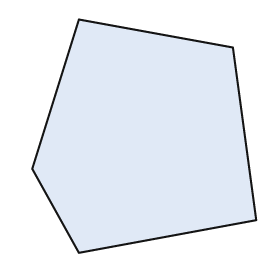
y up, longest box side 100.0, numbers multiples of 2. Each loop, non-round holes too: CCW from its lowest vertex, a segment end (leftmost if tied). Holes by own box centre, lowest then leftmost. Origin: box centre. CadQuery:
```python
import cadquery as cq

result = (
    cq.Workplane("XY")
    .moveTo(-28.0, -50.0)
    .lineTo(48.0, -36.0)
    .lineTo(38.0, 38.0)
    .lineTo(-28.0, 50.0)
    .lineTo(-48.0, -14.0)
    .close()
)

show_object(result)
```